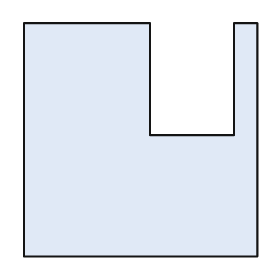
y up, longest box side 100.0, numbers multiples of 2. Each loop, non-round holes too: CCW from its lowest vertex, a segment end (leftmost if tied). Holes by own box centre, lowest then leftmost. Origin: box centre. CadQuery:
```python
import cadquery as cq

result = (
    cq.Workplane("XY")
    .moveTo(-50.0, -50.0)
    .lineTo(50.0, -50.0)
    .lineTo(50.0, 50.0)
    .lineTo(40.0, 50.0)
    .lineTo(40.0, 2.0)
    .lineTo(4.0, 2.0)
    .lineTo(4.0, 50.0)
    .lineTo(-50.0, 50.0)
    .close()
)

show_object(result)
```